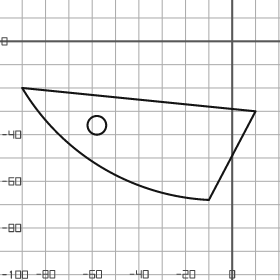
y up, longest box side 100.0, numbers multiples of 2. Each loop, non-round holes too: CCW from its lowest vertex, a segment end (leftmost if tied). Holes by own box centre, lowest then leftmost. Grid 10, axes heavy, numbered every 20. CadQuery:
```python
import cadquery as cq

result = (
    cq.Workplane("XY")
    .moveTo(-10.0, -68.0)
    .lineTo(10.0, -30.0)
    .lineTo(-90.0, -20.0)
    .threePointArc((-56.0, -54.0), (-10.0, -68.0))
    .close()
    .moveTo(-58.0, -36.0)
    .circle(4.0)
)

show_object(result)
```